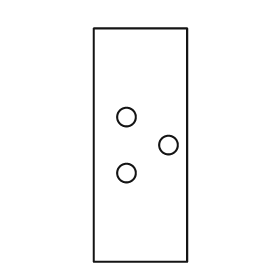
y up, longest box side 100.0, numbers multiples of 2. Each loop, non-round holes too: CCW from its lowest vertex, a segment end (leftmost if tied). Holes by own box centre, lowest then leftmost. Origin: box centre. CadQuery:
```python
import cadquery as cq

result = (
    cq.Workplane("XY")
    .moveTo(-20.0, -50.0)
    .lineTo(20.0, -50.0)
    .lineTo(20.0, 50.0)
    .lineTo(-20.0, 50.0)
    .close()
    .moveTo(-6.0, -12.0)
    .circle(4.0)
    .moveTo(12.0, 0.0)
    .circle(4.0)
    .moveTo(-6.0, 12.0)
    .circle(4.0)
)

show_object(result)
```